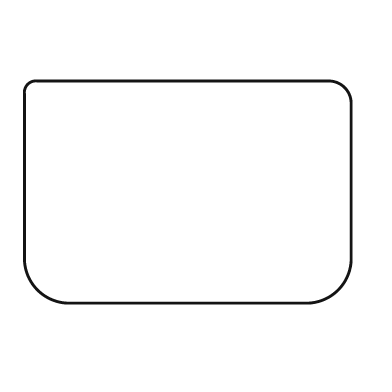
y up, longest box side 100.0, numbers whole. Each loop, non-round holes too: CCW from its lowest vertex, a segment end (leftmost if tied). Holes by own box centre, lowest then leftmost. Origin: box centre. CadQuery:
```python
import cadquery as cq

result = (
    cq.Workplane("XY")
    .moveTo(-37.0, -34.0)
    .lineTo(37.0, -34.0)
    .threePointArc((46.0, -30.0), (50.0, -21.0))
    .lineTo(50.0, 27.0)
    .threePointArc((48.0, 32.0), (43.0, 34.0))
    .lineTo(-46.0, 34.0)
    .threePointArc((-49.0, 33.0), (-50.0, 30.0))
    .lineTo(-50.0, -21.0)
    .threePointArc((-46.0, -30.0), (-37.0, -34.0))
    .close()
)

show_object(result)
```